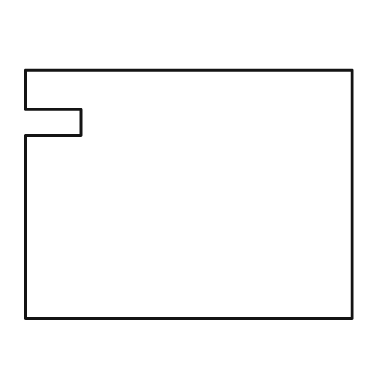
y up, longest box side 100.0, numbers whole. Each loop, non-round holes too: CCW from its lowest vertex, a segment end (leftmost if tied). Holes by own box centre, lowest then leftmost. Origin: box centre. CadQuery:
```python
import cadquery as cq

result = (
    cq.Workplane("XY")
    .moveTo(-50.0, -38.0)
    .lineTo(50.0, -38.0)
    .lineTo(50.0, 38.0)
    .lineTo(-50.0, 38.0)
    .lineTo(-50.0, 26.0)
    .lineTo(-33.0, 26.0)
    .lineTo(-33.0, 18.0)
    .lineTo(-50.0, 18.0)
    .close()
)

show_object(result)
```